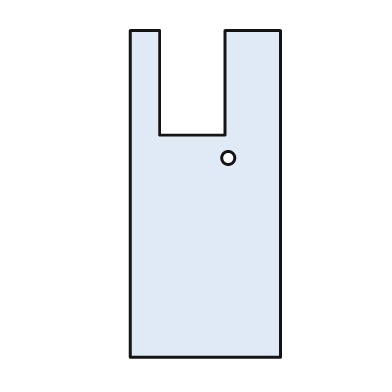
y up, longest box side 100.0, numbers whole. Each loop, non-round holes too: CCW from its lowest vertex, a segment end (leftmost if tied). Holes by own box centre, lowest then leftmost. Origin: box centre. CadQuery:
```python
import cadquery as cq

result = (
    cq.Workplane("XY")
    .moveTo(-23.0, -50.0)
    .lineTo(23.0, -50.0)
    .lineTo(23.0, 50.0)
    .lineTo(6.0, 50.0)
    .lineTo(6.0, 18.0)
    .lineTo(-14.0, 18.0)
    .lineTo(-14.0, 50.0)
    .lineTo(-23.0, 50.0)
    .close()
    .moveTo(7.0, 11.0)
    .circle(2.0)
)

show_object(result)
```